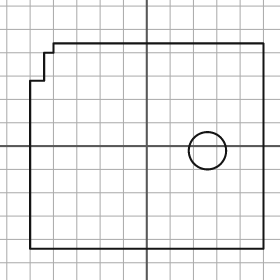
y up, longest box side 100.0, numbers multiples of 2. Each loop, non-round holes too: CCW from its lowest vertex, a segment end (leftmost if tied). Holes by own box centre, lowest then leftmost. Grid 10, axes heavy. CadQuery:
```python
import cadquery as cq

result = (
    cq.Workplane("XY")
    .moveTo(-50.0, -44.0)
    .lineTo(50.0, -44.0)
    .lineTo(50.0, 44.0)
    .lineTo(-40.0, 44.0)
    .lineTo(-40.0, 40.0)
    .lineTo(-44.0, 40.0)
    .lineTo(-44.0, 28.0)
    .lineTo(-50.0, 28.0)
    .close()
    .moveTo(26.0, -2.0)
    .circle(8.0)
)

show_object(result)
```